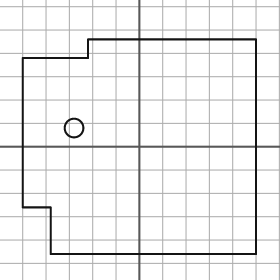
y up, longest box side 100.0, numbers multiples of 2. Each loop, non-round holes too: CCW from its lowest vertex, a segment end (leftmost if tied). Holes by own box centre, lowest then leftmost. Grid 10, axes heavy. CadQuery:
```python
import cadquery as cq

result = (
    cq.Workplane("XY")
    .moveTo(-38.0, -46.0)
    .lineTo(50.0, -46.0)
    .lineTo(50.0, 46.0)
    .lineTo(-22.0, 46.0)
    .lineTo(-22.0, 38.0)
    .lineTo(-50.0, 38.0)
    .lineTo(-50.0, -26.0)
    .lineTo(-38.0, -26.0)
    .close()
    .moveTo(-28.0, 8.0)
    .circle(4.0)
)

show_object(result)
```